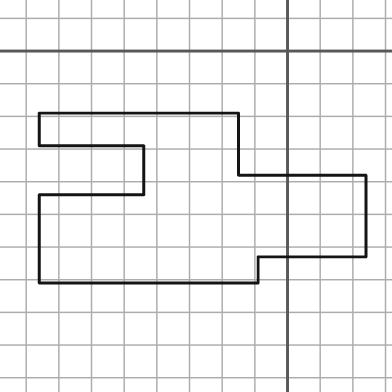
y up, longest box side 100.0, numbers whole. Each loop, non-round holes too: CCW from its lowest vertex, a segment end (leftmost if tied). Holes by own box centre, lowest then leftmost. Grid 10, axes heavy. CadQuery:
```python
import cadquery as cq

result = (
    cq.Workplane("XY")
    .moveTo(-76.0, -71.0)
    .lineTo(-9.0, -71.0)
    .lineTo(-9.0, -63.0)
    .lineTo(24.0, -63.0)
    .lineTo(24.0, -38.0)
    .lineTo(-15.0, -38.0)
    .lineTo(-15.0, -19.0)
    .lineTo(-76.0, -19.0)
    .lineTo(-76.0, -29.0)
    .lineTo(-44.0, -29.0)
    .lineTo(-44.0, -44.0)
    .lineTo(-76.0, -44.0)
    .close()
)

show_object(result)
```